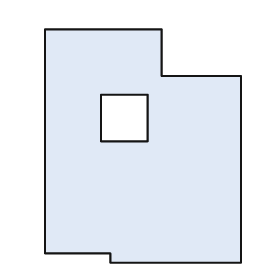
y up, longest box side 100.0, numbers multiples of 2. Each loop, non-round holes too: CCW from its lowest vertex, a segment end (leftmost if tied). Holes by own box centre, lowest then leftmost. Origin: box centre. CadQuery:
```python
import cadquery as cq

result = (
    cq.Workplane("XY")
    .moveTo(-14.0, -50.0)
    .lineTo(42.0, -50.0)
    .lineTo(42.0, 30.0)
    .lineTo(8.0, 30.0)
    .lineTo(8.0, 50.0)
    .lineTo(-42.0, 50.0)
    .lineTo(-42.0, -46.0)
    .lineTo(-14.0, -46.0)
    .close()
    .moveTo(-18.0, 2.0)
    .lineTo(2.0, 2.0)
    .lineTo(2.0, 22.0)
    .lineTo(-18.0, 22.0)
    .close()
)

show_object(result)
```